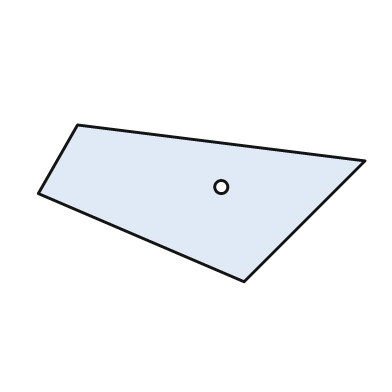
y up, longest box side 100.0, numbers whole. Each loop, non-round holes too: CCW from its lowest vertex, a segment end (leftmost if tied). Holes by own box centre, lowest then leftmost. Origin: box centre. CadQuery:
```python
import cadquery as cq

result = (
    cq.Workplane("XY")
    .moveTo(13.0, -24.0)
    .lineTo(50.0, 13.0)
    .lineTo(-38.0, 24.0)
    .lineTo(-50.0, 3.0)
    .close()
    .moveTo(6.0, 5.0)
    .circle(2.0)
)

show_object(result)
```